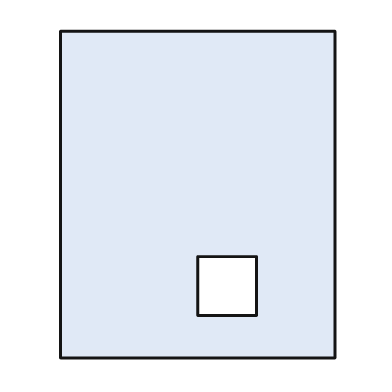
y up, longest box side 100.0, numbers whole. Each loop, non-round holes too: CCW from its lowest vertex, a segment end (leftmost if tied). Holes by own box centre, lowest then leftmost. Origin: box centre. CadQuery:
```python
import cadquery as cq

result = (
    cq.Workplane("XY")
    .moveTo(-42.0, -50.0)
    .lineTo(42.0, -50.0)
    .lineTo(42.0, 50.0)
    .lineTo(-42.0, 50.0)
    .close()
    .moveTo(0.0, -37.0)
    .lineTo(18.0, -37.0)
    .lineTo(18.0, -19.0)
    .lineTo(0.0, -19.0)
    .close()
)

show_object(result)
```